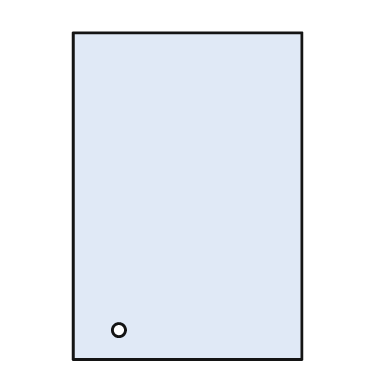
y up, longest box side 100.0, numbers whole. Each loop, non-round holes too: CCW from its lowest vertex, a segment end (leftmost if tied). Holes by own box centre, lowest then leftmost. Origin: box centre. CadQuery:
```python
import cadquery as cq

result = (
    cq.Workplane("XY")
    .moveTo(-35.0, -50.0)
    .lineTo(35.0, -50.0)
    .lineTo(35.0, 50.0)
    .lineTo(-35.0, 50.0)
    .close()
    .moveTo(-21.0, -41.0)
    .circle(2.0)
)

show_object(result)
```